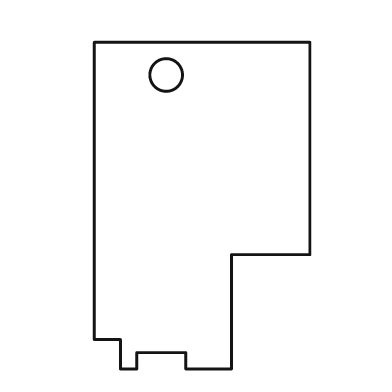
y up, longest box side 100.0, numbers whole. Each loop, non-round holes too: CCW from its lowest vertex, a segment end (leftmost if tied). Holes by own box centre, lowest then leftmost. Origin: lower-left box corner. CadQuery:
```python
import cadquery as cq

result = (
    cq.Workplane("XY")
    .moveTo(8.0, 0.0)
    .lineTo(13.0, 0.0)
    .lineTo(13.0, 5.0)
    .lineTo(28.0, 5.0)
    .lineTo(28.0, 0.0)
    .lineTo(42.0, 0.0)
    .lineTo(42.0, 35.0)
    .lineTo(66.0, 35.0)
    .lineTo(66.0, 100.0)
    .lineTo(0.0, 100.0)
    .lineTo(0.0, 9.0)
    .lineTo(8.0, 9.0)
    .close()
    .moveTo(22.0, 90.0)
    .circle(5.0)
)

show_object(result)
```